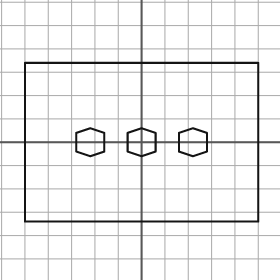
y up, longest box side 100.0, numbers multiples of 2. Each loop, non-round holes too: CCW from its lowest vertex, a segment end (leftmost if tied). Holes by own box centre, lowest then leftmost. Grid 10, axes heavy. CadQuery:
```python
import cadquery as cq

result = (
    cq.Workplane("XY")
    .moveTo(-50.0, -34.0)
    .lineTo(50.0, -34.0)
    .lineTo(50.0, 34.0)
    .lineTo(-50.0, 34.0)
    .close()
    .moveTo(-22.0, -6.0)
    .lineTo(-16.0, -4.0)
    .lineTo(-16.0, 4.0)
    .lineTo(-22.0, 6.0)
    .lineTo(-28.0, 4.0)
    .lineTo(-28.0, -4.0)
    .close()
    .moveTo(0.0, -6.0)
    .lineTo(6.0, -4.0)
    .lineTo(6.0, 4.0)
    .lineTo(0.0, 6.0)
    .lineTo(-6.0, 4.0)
    .lineTo(-6.0, -4.0)
    .close()
    .moveTo(22.0, -6.0)
    .lineTo(28.0, -4.0)
    .lineTo(28.0, 4.0)
    .lineTo(22.0, 6.0)
    .lineTo(16.0, 4.0)
    .lineTo(16.0, -4.0)
    .close()
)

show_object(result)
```